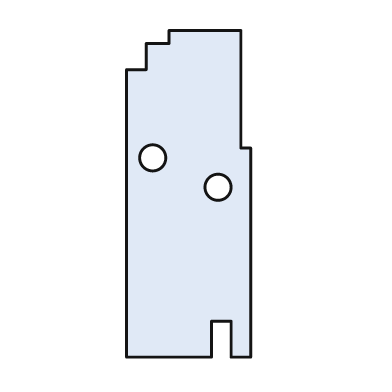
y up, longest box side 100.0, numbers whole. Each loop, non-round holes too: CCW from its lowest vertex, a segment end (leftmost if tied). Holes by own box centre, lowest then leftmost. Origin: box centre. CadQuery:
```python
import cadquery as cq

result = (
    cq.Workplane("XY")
    .moveTo(-19.0, -50.0)
    .lineTo(7.0, -50.0)
    .lineTo(7.0, -39.0)
    .lineTo(13.0, -39.0)
    .lineTo(13.0, -50.0)
    .lineTo(19.0, -50.0)
    .lineTo(19.0, 14.0)
    .lineTo(16.0, 14.0)
    .lineTo(16.0, 50.0)
    .lineTo(-6.0, 50.0)
    .lineTo(-6.0, 46.0)
    .lineTo(-13.0, 46.0)
    .lineTo(-13.0, 38.0)
    .lineTo(-19.0, 38.0)
    .close()
    .moveTo(9.0, 2.0)
    .circle(4.0)
    .moveTo(-11.0, 11.0)
    .circle(4.0)
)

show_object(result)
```